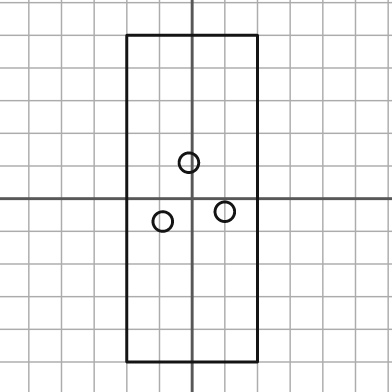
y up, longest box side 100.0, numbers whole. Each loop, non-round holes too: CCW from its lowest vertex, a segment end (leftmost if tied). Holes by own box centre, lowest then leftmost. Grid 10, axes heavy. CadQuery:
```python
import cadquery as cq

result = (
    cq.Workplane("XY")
    .moveTo(-20.0, -50.0)
    .lineTo(20.0, -50.0)
    .lineTo(20.0, 50.0)
    .lineTo(-20.0, 50.0)
    .close()
    .moveTo(-9.0, -7.0)
    .circle(3.0)
    .moveTo(10.0, -4.0)
    .circle(3.0)
    .moveTo(-1.0, 11.0)
    .circle(3.0)
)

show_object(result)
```